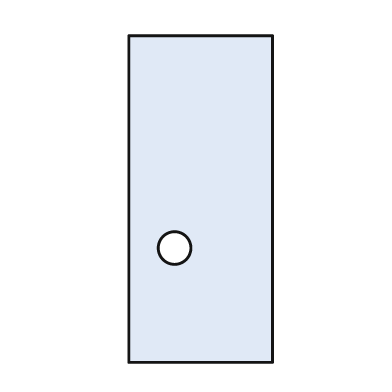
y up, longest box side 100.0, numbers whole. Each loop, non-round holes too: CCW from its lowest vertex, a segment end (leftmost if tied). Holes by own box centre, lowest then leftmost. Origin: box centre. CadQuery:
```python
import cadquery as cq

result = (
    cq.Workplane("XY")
    .moveTo(-22.0, -50.0)
    .lineTo(22.0, -50.0)
    .lineTo(22.0, 50.0)
    .lineTo(-22.0, 50.0)
    .close()
    .moveTo(-8.0, -15.0)
    .circle(5.0)
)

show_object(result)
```